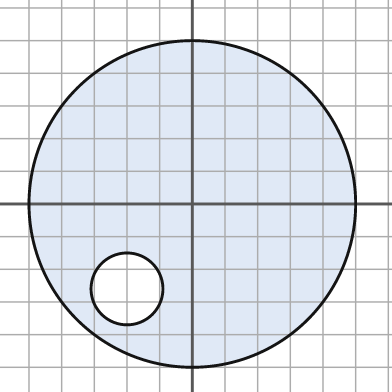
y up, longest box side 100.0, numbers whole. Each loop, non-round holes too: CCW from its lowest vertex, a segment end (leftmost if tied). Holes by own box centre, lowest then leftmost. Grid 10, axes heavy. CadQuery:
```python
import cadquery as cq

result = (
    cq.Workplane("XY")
    .moveTo(0.0, 0.0)
    .circle(50.0)
    .moveTo(-20.0, -26.0)
    .circle(11.0)
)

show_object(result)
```